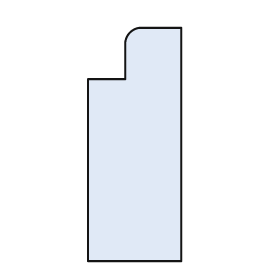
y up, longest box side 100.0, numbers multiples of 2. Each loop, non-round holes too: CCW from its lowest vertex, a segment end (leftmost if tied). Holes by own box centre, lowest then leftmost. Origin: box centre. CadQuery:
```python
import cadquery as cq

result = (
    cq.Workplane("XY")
    .moveTo(-20.0, -50.0)
    .lineTo(20.0, -50.0)
    .lineTo(20.0, 50.0)
    .lineTo(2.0, 50.0)
    .threePointArc((-2.0, 48.0), (-4.0, 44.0))
    .lineTo(-4.0, 28.0)
    .lineTo(-20.0, 28.0)
    .close()
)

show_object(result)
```